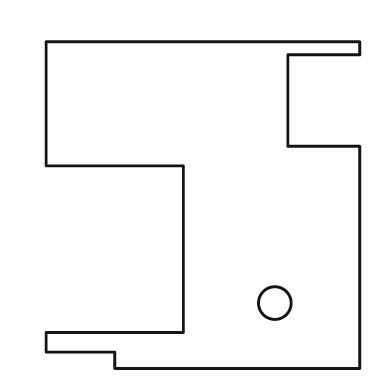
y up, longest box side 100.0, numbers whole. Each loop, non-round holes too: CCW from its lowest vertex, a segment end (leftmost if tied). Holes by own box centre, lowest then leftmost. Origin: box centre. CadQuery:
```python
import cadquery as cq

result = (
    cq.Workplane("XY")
    .moveTo(-27.0, -50.0)
    .lineTo(48.0, -50.0)
    .lineTo(48.0, 18.0)
    .lineTo(26.0, 18.0)
    .lineTo(26.0, 46.0)
    .lineTo(48.0, 46.0)
    .lineTo(48.0, 50.0)
    .lineTo(-48.0, 50.0)
    .lineTo(-48.0, 12.0)
    .lineTo(-6.0, 12.0)
    .lineTo(-6.0, -39.0)
    .lineTo(-48.0, -39.0)
    .lineTo(-48.0, -45.0)
    .lineTo(-27.0, -45.0)
    .close()
    .moveTo(22.0, -30.0)
    .circle(5.0)
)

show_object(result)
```